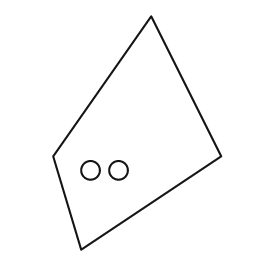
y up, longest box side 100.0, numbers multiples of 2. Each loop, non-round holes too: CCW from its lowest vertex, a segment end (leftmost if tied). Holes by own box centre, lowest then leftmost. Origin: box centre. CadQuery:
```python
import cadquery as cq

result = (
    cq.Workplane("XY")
    .moveTo(-24.0, -50.0)
    .lineTo(36.0, -10.0)
    .lineTo(6.0, 50.0)
    .lineTo(-36.0, -10.0)
    .close()
    .moveTo(-20.0, -16.0)
    .circle(4.0)
    .moveTo(-8.0, -16.0)
    .circle(4.0)
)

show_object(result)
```